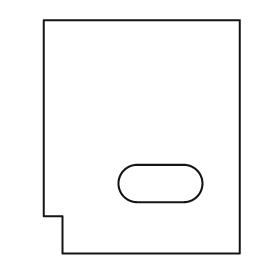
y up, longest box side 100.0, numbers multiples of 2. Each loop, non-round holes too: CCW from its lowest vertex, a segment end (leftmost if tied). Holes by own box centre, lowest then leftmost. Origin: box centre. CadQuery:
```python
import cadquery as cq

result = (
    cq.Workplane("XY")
    .moveTo(-34.0, -50.0)
    .lineTo(42.0, -50.0)
    .lineTo(42.0, 50.0)
    .lineTo(-42.0, 50.0)
    .lineTo(-42.0, -34.0)
    .lineTo(-34.0, -34.0)
    .close()
    .moveTo(-2.0, -28.0)
    .lineTo(18.0, -28.0)
    .threePointArc((26.0, -20.0), (18.0, -12.0))
    .lineTo(-2.0, -12.0)
    .threePointArc((-10.0, -20.0), (-2.0, -28.0))
    .close()
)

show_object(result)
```